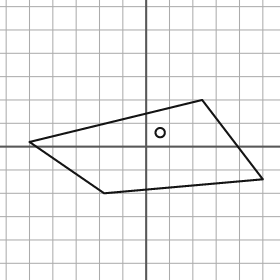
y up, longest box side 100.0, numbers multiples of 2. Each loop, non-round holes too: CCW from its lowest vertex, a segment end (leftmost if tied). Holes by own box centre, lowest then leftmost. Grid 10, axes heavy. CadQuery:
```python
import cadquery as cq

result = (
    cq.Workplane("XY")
    .moveTo(-18.0, -20.0)
    .lineTo(50.0, -14.0)
    .lineTo(24.0, 20.0)
    .lineTo(-50.0, 2.0)
    .close()
    .moveTo(6.0, 6.0)
    .circle(2.0)
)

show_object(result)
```